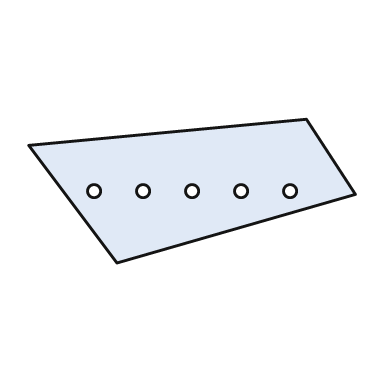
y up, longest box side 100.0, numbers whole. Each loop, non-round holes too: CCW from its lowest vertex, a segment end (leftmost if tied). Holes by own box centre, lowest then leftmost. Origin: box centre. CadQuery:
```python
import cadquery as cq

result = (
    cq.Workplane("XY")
    .moveTo(-23.0, -22.0)
    .lineTo(50.0, -1.0)
    .lineTo(35.0, 22.0)
    .lineTo(-50.0, 14.0)
    .close()
    .moveTo(-30.0, 0.0)
    .circle(2.0)
    .moveTo(-15.0, 0.0)
    .circle(2.0)
    .moveTo(0.0, 0.0)
    .circle(2.0)
    .moveTo(15.0, 0.0)
    .circle(2.0)
    .moveTo(30.0, 0.0)
    .circle(2.0)
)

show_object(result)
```